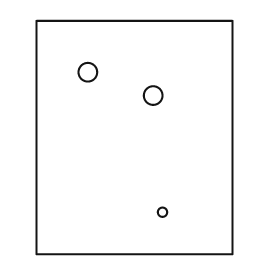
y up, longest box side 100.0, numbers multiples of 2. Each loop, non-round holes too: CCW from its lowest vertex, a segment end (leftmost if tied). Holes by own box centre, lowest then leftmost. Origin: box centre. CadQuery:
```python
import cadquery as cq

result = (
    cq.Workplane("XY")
    .moveTo(-42.0, -50.0)
    .lineTo(42.0, -50.0)
    .lineTo(42.0, 50.0)
    .lineTo(-42.0, 50.0)
    .close()
    .moveTo(12.0, -32.0)
    .circle(2.0)
    .moveTo(8.0, 18.0)
    .circle(4.0)
    .moveTo(-20.0, 28.0)
    .circle(4.0)
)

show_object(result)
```